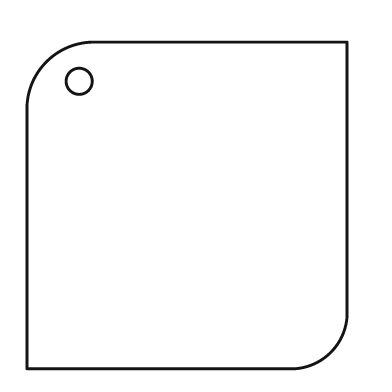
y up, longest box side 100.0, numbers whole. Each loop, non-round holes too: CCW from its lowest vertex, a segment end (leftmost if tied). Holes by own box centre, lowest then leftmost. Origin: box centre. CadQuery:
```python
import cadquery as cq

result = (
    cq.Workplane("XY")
    .moveTo(-49.0, -50.0)
    .lineTo(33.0, -50.0)
    .threePointArc((44.0, -45.0), (49.0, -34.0))
    .lineTo(49.0, 50.0)
    .lineTo(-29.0, 50.0)
    .threePointArc((-43.0, 44.0), (-49.0, 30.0))
    .close()
    .moveTo(-33.0, 38.0)
    .circle(4.0)
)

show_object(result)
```